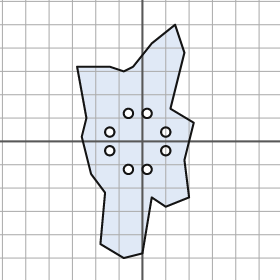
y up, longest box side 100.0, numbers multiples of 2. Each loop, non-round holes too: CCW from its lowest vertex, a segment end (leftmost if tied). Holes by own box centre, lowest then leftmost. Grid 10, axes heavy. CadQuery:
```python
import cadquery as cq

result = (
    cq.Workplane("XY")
    .moveTo(-8.0, -50.0)
    .lineTo(0.0, -48.0)
    .lineTo(4.0, -24.0)
    .lineTo(10.0, -28.0)
    .lineTo(20.0, -24.0)
    .lineTo(18.0, -8.0)
    .lineTo(22.0, 8.0)
    .lineTo(12.0, 14.0)
    .lineTo(18.0, 38.0)
    .lineTo(14.0, 50.0)
    .lineTo(4.0, 42.0)
    .lineTo(-4.0, 32.0)
    .lineTo(-8.0, 30.0)
    .lineTo(-14.0, 32.0)
    .lineTo(-28.0, 32.0)
    .lineTo(-24.0, 10.0)
    .lineTo(-26.0, 2.0)
    .lineTo(-22.0, -14.0)
    .lineTo(-16.0, -22.0)
    .lineTo(-18.0, -44.0)
    .close()
    .moveTo(-6.0, -12.0)
    .circle(2.0)
    .moveTo(2.0, -12.0)
    .circle(2.0)
    .moveTo(-14.0, -4.0)
    .circle(2.0)
    .moveTo(10.0, -4.0)
    .circle(2.0)
    .moveTo(-14.0, 4.0)
    .circle(2.0)
    .moveTo(10.0, 4.0)
    .circle(2.0)
    .moveTo(-6.0, 12.0)
    .circle(2.0)
    .moveTo(2.0, 12.0)
    .circle(2.0)
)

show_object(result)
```